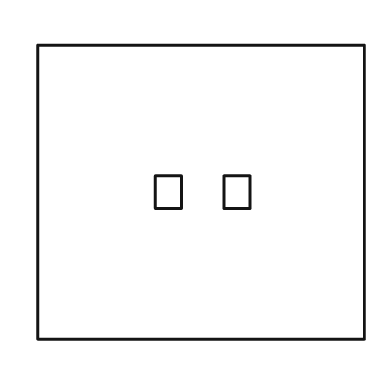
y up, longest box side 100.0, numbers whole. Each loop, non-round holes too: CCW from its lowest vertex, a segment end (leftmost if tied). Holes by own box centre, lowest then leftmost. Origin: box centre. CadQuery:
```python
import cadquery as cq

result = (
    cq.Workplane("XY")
    .moveTo(-50.0, -45.0)
    .lineTo(50.0, -45.0)
    .lineTo(50.0, 45.0)
    .lineTo(-50.0, 45.0)
    .close()
    .moveTo(-14.0, -5.0)
    .lineTo(-6.0, -5.0)
    .lineTo(-6.0, 5.0)
    .lineTo(-14.0, 5.0)
    .close()
    .moveTo(7.0, -5.0)
    .lineTo(15.0, -5.0)
    .lineTo(15.0, 5.0)
    .lineTo(7.0, 5.0)
    .close()
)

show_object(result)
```